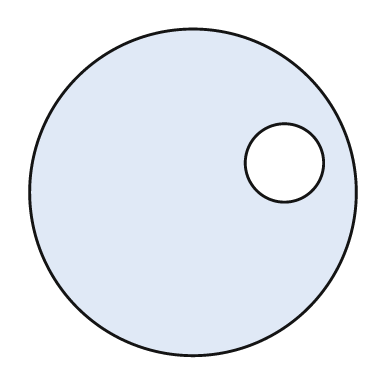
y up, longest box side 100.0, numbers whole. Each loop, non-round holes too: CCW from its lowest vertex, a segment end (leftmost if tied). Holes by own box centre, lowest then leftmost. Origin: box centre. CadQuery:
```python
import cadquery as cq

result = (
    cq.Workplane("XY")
    .moveTo(0.0, 0.0)
    .circle(50.0)
    .moveTo(28.0, 9.0)
    .circle(12.0)
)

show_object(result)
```